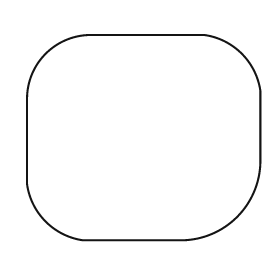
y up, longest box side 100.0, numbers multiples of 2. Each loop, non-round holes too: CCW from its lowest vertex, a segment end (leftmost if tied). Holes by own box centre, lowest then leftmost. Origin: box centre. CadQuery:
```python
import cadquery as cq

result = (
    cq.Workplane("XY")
    .moveTo(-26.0, -44.0)
    .lineTo(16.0, -44.0)
    .threePointArc((40.0, -34.0), (50.0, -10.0))
    .lineTo(50.0, 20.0)
    .threePointArc((42.0, 36.0), (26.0, 44.0))
    .lineTo(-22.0, 44.0)
    .threePointArc((-42.0, 36.0), (-50.0, 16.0))
    .lineTo(-50.0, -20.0)
    .threePointArc((-42.0, -36.0), (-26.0, -44.0))
    .close()
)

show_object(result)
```